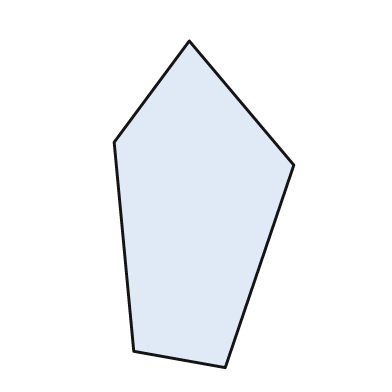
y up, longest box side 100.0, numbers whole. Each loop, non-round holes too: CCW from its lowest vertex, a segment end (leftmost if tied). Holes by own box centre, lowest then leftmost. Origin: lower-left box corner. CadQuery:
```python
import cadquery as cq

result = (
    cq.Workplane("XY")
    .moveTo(34.0, 0.0)
    .lineTo(55.0, 62.0)
    .lineTo(23.0, 100.0)
    .lineTo(0.0, 69.0)
    .lineTo(6.0, 5.0)
    .close()
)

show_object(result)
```